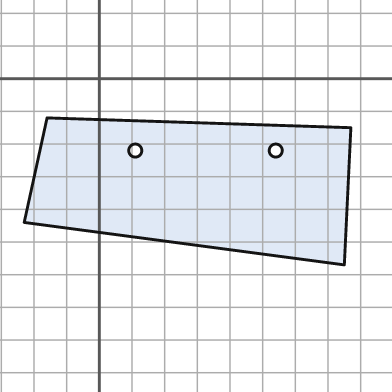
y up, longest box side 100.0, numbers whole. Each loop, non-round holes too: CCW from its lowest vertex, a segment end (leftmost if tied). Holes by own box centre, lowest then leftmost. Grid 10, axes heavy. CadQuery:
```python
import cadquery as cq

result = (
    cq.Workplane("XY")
    .moveTo(75.0, -57.0)
    .lineTo(77.0, -15.0)
    .lineTo(-16.0, -12.0)
    .lineTo(-23.0, -44.0)
    .close()
    .moveTo(11.0, -22.0)
    .circle(2.0)
    .moveTo(54.0, -22.0)
    .circle(2.0)
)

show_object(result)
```